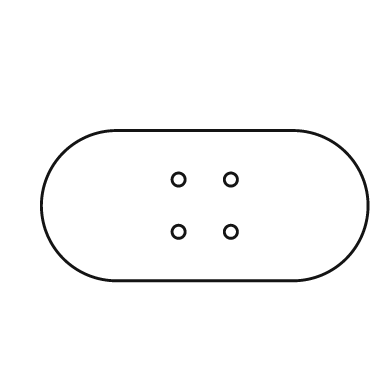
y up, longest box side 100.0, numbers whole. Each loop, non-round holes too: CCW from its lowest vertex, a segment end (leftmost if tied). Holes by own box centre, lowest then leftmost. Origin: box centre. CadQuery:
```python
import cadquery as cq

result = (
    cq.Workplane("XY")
    .moveTo(-27.0, -23.0)
    .lineTo(27.0, -23.0)
    .threePointArc((50.0, 0.0), (27.0, 23.0))
    .lineTo(-27.0, 23.0)
    .threePointArc((-50.0, 0.0), (-27.0, -23.0))
    .close()
    .moveTo(-8.0, -8.0)
    .circle(2.0)
    .moveTo(8.0, -8.0)
    .circle(2.0)
    .moveTo(-8.0, 8.0)
    .circle(2.0)
    .moveTo(8.0, 8.0)
    .circle(2.0)
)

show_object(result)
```